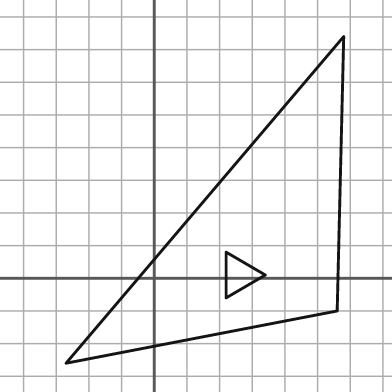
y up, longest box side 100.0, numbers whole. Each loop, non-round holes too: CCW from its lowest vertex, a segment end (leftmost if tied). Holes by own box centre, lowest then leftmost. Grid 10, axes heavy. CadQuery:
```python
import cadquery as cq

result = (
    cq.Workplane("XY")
    .moveTo(-27.0, -26.0)
    .lineTo(56.0, -10.0)
    .lineTo(58.0, 74.0)
    .close()
    .moveTo(22.0, -6.0)
    .lineTo(34.0, 1.0)
    .lineTo(22.0, 8.0)
    .close()
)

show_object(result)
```